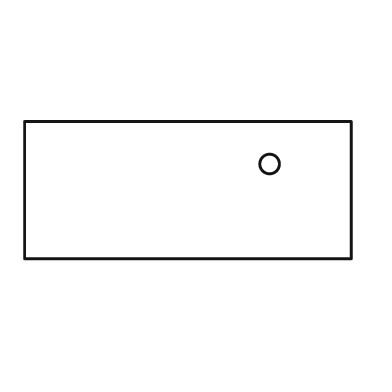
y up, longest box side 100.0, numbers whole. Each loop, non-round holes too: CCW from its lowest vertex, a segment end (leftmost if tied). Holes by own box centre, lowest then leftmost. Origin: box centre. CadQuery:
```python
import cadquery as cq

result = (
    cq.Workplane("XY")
    .moveTo(-50.0, -21.0)
    .lineTo(50.0, -21.0)
    .lineTo(50.0, 21.0)
    .lineTo(-50.0, 21.0)
    .close()
    .moveTo(25.0, 8.0)
    .circle(3.0)
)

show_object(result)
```